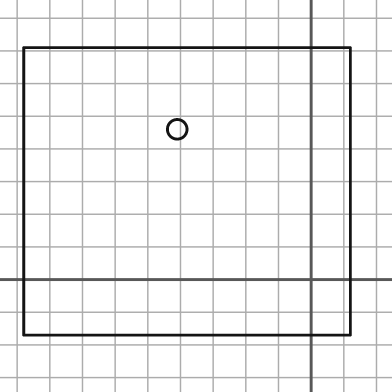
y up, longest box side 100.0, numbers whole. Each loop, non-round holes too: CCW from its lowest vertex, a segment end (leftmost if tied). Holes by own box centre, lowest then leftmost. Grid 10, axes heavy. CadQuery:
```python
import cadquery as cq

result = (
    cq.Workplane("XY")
    .moveTo(-88.0, -17.0)
    .lineTo(12.0, -17.0)
    .lineTo(12.0, 71.0)
    .lineTo(-88.0, 71.0)
    .close()
    .moveTo(-41.0, 46.0)
    .circle(3.0)
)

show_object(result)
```